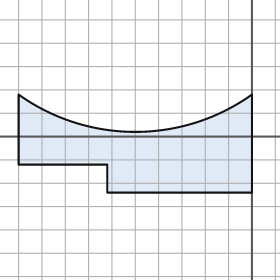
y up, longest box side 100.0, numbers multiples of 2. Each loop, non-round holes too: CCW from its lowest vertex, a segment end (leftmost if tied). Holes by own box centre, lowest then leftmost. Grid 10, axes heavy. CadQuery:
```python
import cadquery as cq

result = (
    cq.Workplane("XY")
    .moveTo(-62.0, -24.0)
    .lineTo(0.0, -24.0)
    .lineTo(0.0, 18.0)
    .threePointArc((-50.0, 2.0), (-100.0, 18.0))
    .lineTo(-100.0, -12.0)
    .lineTo(-62.0, -12.0)
    .close()
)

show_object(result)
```